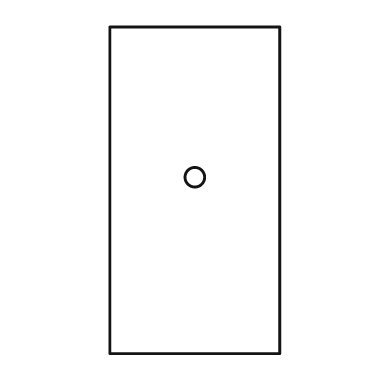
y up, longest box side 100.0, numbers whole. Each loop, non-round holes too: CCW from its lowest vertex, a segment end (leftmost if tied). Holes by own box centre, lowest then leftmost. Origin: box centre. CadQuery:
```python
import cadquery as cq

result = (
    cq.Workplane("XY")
    .moveTo(-26.0, -50.0)
    .lineTo(26.0, -50.0)
    .lineTo(26.0, 50.0)
    .lineTo(-26.0, 50.0)
    .close()
    .moveTo(0.0, 4.0)
    .circle(3.0)
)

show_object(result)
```